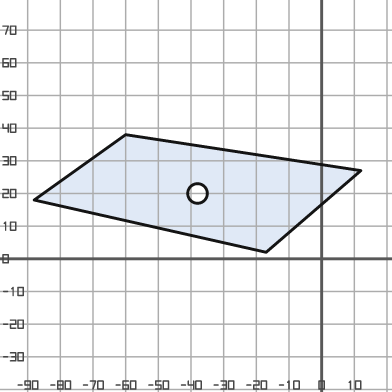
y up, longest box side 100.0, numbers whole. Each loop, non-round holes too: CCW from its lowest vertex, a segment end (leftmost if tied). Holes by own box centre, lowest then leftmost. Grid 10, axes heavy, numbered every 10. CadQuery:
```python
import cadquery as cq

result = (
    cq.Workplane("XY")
    .moveTo(-17.0, 2.0)
    .lineTo(12.0, 27.0)
    .lineTo(-60.0, 38.0)
    .lineTo(-88.0, 18.0)
    .close()
    .moveTo(-38.0, 20.0)
    .circle(3.0)
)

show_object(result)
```